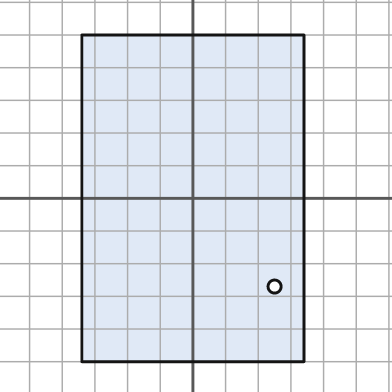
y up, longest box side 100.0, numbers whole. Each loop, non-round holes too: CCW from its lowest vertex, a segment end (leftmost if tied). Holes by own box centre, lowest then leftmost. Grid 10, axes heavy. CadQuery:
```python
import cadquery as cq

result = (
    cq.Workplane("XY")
    .moveTo(-34.0, -50.0)
    .lineTo(34.0, -50.0)
    .lineTo(34.0, 50.0)
    .lineTo(-34.0, 50.0)
    .close()
    .moveTo(25.0, -27.0)
    .circle(2.0)
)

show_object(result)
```